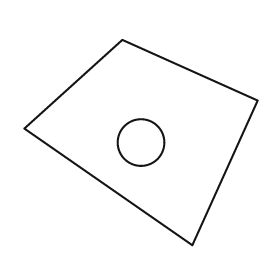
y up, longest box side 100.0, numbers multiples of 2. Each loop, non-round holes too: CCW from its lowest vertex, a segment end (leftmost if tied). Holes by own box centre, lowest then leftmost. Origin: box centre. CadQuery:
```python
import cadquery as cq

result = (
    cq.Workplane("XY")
    .moveTo(22.0, -44.0)
    .lineTo(50.0, 18.0)
    .lineTo(-8.0, 44.0)
    .lineTo(-50.0, 6.0)
    .close()
    .moveTo(0.0, 0.0)
    .circle(10.0)
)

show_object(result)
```